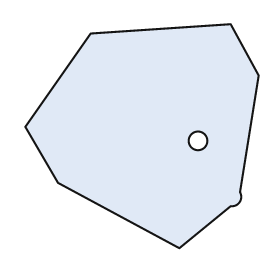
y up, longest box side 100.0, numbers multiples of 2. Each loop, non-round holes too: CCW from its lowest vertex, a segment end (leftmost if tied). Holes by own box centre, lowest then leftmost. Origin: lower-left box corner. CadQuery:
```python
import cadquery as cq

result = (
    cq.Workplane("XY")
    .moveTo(66.0, 0.0)
    .lineTo(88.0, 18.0)
    .threePointArc((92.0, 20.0), (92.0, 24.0))
    .lineTo(100.0, 74.0)
    .lineTo(88.0, 96.0)
    .lineTo(28.0, 92.0)
    .lineTo(0.0, 52.0)
    .lineTo(14.0, 28.0)
    .close()
    .moveTo(74.0, 46.0)
    .circle(4.0)
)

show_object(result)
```